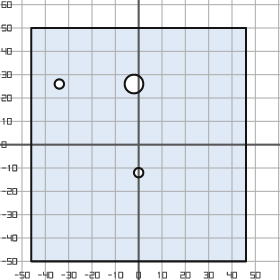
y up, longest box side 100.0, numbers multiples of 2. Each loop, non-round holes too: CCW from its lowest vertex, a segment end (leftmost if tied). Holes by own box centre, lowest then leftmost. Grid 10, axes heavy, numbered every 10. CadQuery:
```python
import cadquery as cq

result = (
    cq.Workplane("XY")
    .moveTo(-46.0, -50.0)
    .lineTo(46.0, -50.0)
    .lineTo(46.0, 50.0)
    .lineTo(-46.0, 50.0)
    .close()
    .moveTo(0.0, -12.0)
    .circle(2.0)
    .moveTo(-34.0, 26.0)
    .circle(2.0)
    .moveTo(-2.0, 26.0)
    .circle(4.0)
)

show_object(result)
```